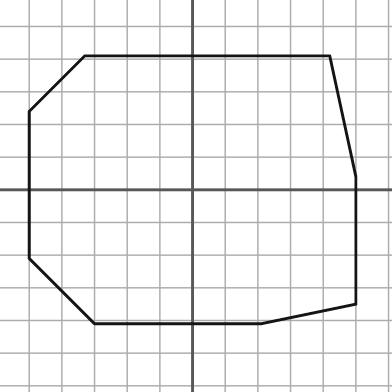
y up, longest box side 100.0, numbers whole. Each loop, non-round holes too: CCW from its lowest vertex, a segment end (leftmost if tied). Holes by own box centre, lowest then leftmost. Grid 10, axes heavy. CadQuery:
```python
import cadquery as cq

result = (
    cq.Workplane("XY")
    .moveTo(-30.0, -41.0)
    .lineTo(21.0, -41.0)
    .lineTo(50.0, -35.0)
    .lineTo(50.0, 4.0)
    .lineTo(42.0, 41.0)
    .lineTo(-33.0, 41.0)
    .lineTo(-50.0, 24.0)
    .lineTo(-50.0, -21.0)
    .close()
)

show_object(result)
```